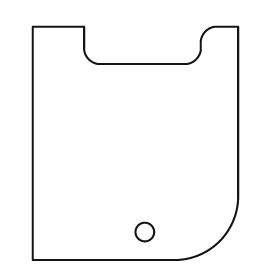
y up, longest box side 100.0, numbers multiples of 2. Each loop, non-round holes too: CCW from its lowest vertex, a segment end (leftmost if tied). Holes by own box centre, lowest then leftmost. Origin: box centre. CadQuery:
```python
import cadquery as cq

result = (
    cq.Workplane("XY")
    .moveTo(-44.0, -50.0)
    .lineTo(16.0, -50.0)
    .threePointArc((36.0, -42.0), (44.0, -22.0))
    .lineTo(44.0, 50.0)
    .lineTo(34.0, 50.0)
    .threePointArc((30.0, 48.0), (28.0, 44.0))
    .lineTo(28.0, 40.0)
    .threePointArc((26.0, 36.0), (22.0, 34.0))
    .lineTo(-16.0, 34.0)
    .threePointArc((-20.0, 36.0), (-22.0, 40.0))
    .lineTo(-22.0, 50.0)
    .lineTo(-44.0, 50.0)
    .close()
    .moveTo(4.0, -38.0)
    .circle(4.0)
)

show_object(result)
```